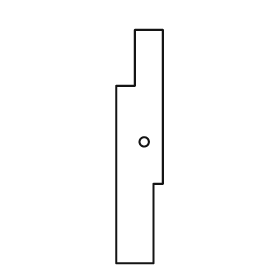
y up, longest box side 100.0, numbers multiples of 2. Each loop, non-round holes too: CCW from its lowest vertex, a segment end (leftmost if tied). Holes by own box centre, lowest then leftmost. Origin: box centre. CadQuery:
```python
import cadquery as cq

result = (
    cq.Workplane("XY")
    .moveTo(-10.0, -50.0)
    .lineTo(6.0, -50.0)
    .lineTo(6.0, -16.0)
    .lineTo(10.0, -16.0)
    .lineTo(10.0, 50.0)
    .lineTo(-2.0, 50.0)
    .lineTo(-2.0, 26.0)
    .lineTo(-10.0, 26.0)
    .close()
    .moveTo(2.0, 2.0)
    .circle(2.0)
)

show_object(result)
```